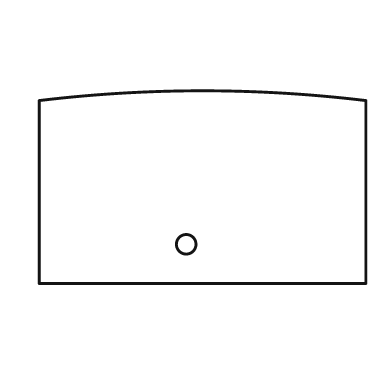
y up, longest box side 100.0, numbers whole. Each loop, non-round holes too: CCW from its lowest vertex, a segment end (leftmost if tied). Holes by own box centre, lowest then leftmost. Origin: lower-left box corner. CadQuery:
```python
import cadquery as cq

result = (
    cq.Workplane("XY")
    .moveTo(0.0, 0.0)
    .lineTo(100.0, 0.0)
    .lineTo(100.0, 56.0)
    .threePointArc((50.0, 59.0), (0.0, 56.0))
    .close()
    .moveTo(45.0, 12.0)
    .circle(3.0)
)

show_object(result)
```